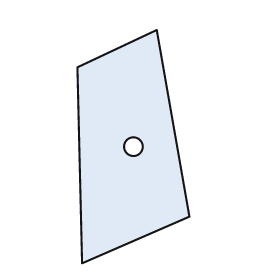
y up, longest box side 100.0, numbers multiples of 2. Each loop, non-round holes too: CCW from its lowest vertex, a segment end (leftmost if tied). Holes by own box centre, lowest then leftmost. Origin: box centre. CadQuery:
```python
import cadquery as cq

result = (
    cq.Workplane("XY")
    .moveTo(-22.0, -50.0)
    .lineTo(24.0, -30.0)
    .lineTo(10.0, 50.0)
    .lineTo(-24.0, 34.0)
    .close()
    .moveTo(0.0, 0.0)
    .circle(4.0)
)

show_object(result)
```